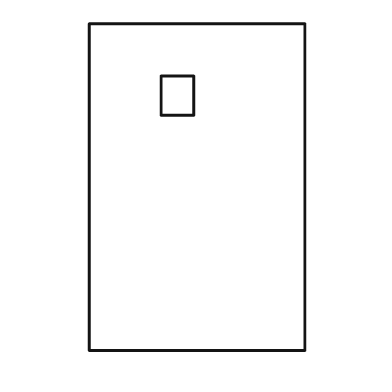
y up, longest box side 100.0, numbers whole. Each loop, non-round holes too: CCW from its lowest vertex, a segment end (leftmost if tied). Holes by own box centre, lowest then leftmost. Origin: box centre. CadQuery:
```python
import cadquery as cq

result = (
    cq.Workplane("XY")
    .moveTo(-33.0, -50.0)
    .lineTo(33.0, -50.0)
    .lineTo(33.0, 50.0)
    .lineTo(-33.0, 50.0)
    .close()
    .moveTo(-11.0, 22.0)
    .lineTo(-1.0, 22.0)
    .lineTo(-1.0, 34.0)
    .lineTo(-11.0, 34.0)
    .close()
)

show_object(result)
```